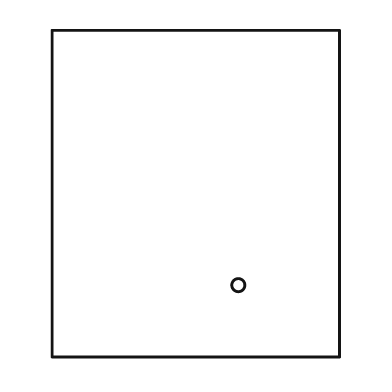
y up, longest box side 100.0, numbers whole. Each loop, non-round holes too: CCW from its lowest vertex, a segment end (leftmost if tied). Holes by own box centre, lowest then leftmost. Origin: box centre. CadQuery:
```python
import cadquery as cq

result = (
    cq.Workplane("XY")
    .moveTo(-44.0, -50.0)
    .lineTo(44.0, -50.0)
    .lineTo(44.0, 50.0)
    .lineTo(-44.0, 50.0)
    .close()
    .moveTo(13.0, -28.0)
    .circle(2.0)
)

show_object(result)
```